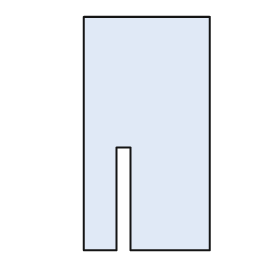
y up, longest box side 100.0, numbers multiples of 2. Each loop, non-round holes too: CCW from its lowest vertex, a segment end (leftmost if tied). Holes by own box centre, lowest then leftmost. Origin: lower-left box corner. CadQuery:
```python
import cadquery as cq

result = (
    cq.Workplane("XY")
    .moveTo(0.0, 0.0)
    .lineTo(14.0, 0.0)
    .lineTo(14.0, 44.0)
    .lineTo(20.0, 44.0)
    .lineTo(20.0, 0.0)
    .lineTo(54.0, 0.0)
    .lineTo(54.0, 100.0)
    .lineTo(0.0, 100.0)
    .close()
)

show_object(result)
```